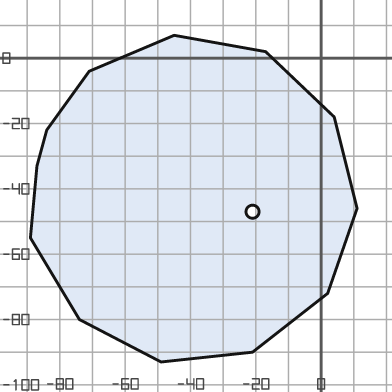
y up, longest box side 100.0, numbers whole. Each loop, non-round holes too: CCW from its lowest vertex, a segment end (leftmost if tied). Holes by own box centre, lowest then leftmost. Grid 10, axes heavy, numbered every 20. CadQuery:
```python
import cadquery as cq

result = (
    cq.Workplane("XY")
    .moveTo(-49.0, -93.0)
    .lineTo(-21.0, -90.0)
    .lineTo(2.0, -72.0)
    .lineTo(11.0, -46.0)
    .lineTo(4.0, -18.0)
    .lineTo(-17.0, 2.0)
    .lineTo(-45.0, 7.0)
    .lineTo(-71.0, -4.0)
    .lineTo(-84.0, -22.0)
    .lineTo(-87.0, -33.0)
    .lineTo(-89.0, -55.0)
    .lineTo(-74.0, -80.0)
    .close()
    .moveTo(-21.0, -47.0)
    .circle(2.0)
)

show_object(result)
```